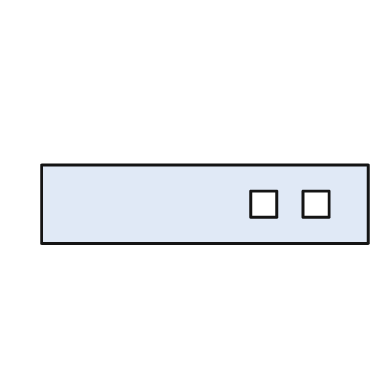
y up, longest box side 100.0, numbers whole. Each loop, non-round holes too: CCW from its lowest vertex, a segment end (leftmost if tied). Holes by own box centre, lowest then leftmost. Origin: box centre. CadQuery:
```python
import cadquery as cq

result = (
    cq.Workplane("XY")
    .moveTo(-50.0, -12.0)
    .lineTo(50.0, -12.0)
    .lineTo(50.0, 12.0)
    .lineTo(-50.0, 12.0)
    .close()
    .moveTo(14.0, -4.0)
    .lineTo(22.0, -4.0)
    .lineTo(22.0, 4.0)
    .lineTo(14.0, 4.0)
    .close()
    .moveTo(30.0, -4.0)
    .lineTo(38.0, -4.0)
    .lineTo(38.0, 4.0)
    .lineTo(30.0, 4.0)
    .close()
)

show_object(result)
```